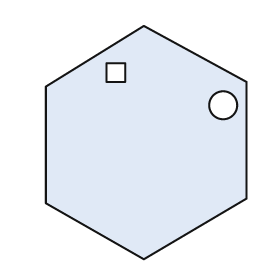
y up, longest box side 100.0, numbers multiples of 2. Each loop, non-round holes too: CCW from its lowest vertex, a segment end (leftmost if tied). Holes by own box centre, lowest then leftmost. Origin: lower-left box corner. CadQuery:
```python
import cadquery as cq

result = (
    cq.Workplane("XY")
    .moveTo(42.0, 0.0)
    .lineTo(86.0, 26.0)
    .lineTo(86.0, 76.0)
    .lineTo(42.0, 100.0)
    .lineTo(0.0, 74.0)
    .lineTo(0.0, 24.0)
    .close()
    .moveTo(76.0, 66.0)
    .circle(6.0)
    .moveTo(26.0, 76.0)
    .lineTo(34.0, 76.0)
    .lineTo(34.0, 84.0)
    .lineTo(26.0, 84.0)
    .close()
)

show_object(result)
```